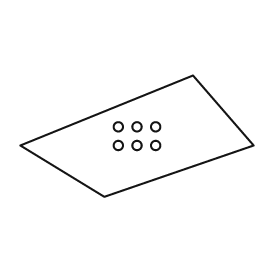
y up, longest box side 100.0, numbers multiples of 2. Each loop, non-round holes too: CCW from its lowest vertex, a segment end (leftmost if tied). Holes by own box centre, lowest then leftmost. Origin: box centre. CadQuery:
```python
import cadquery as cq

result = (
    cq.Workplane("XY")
    .moveTo(-14.0, -26.0)
    .lineTo(50.0, -4.0)
    .lineTo(24.0, 26.0)
    .lineTo(-50.0, -4.0)
    .close()
    .moveTo(-8.0, -4.0)
    .circle(2.0)
    .moveTo(0.0, -4.0)
    .circle(2.0)
    .moveTo(8.0, -4.0)
    .circle(2.0)
    .moveTo(-8.0, 4.0)
    .circle(2.0)
    .moveTo(0.0, 4.0)
    .circle(2.0)
    .moveTo(8.0, 4.0)
    .circle(2.0)
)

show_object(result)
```